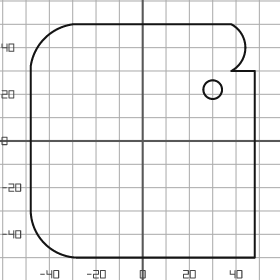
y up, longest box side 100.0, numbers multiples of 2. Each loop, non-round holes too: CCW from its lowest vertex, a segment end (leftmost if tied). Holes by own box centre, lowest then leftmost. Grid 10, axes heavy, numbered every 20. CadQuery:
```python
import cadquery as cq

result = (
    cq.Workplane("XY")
    .moveTo(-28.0, -50.0)
    .lineTo(48.0, -50.0)
    .lineTo(48.0, 30.0)
    .lineTo(38.0, 30.0)
    .threePointArc((44.0, 40.0), (38.0, 50.0))
    .lineTo(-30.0, 50.0)
    .threePointArc((-42.0, 44.0), (-48.0, 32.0))
    .lineTo(-48.0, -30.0)
    .threePointArc((-42.0, -44.0), (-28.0, -50.0))
    .close()
    .moveTo(30.0, 22.0)
    .circle(4.0)
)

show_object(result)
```